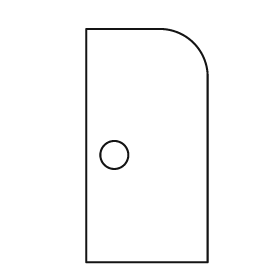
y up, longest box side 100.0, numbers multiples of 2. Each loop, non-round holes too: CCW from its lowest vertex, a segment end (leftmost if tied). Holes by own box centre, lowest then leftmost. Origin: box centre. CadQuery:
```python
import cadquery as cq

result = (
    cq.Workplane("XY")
    .moveTo(-26.0, -50.0)
    .lineTo(26.0, -50.0)
    .lineTo(26.0, 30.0)
    .threePointArc((20.0, 44.0), (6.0, 50.0))
    .lineTo(-26.0, 50.0)
    .close()
    .moveTo(-14.0, -4.0)
    .circle(6.0)
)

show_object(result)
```